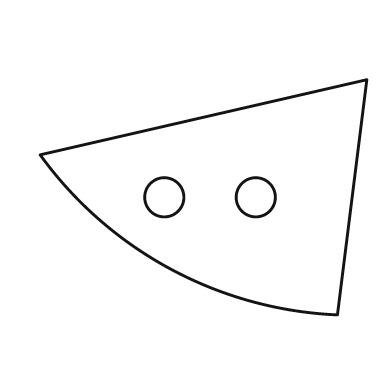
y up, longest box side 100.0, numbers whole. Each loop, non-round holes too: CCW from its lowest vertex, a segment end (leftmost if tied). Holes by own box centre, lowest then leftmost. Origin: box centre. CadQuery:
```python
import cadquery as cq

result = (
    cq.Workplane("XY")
    .moveTo(41.0, -36.0)
    .lineTo(50.0, 36.0)
    .lineTo(-50.0, 13.0)
    .threePointArc((-10.0, -22.0), (41.0, -36.0))
    .close()
    .moveTo(-12.0, 0.0)
    .circle(6.0)
    .moveTo(16.0, 0.0)
    .circle(6.0)
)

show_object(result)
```